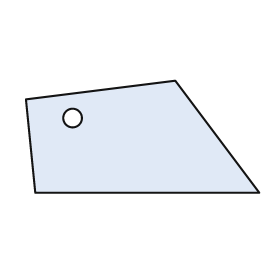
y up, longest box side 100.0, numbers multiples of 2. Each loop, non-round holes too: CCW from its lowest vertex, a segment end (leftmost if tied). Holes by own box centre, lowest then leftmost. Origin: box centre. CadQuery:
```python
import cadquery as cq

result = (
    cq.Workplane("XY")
    .moveTo(-46.0, -24.0)
    .lineTo(50.0, -24.0)
    .lineTo(14.0, 24.0)
    .lineTo(-50.0, 16.0)
    .close()
    .moveTo(-30.0, 8.0)
    .circle(4.0)
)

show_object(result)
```